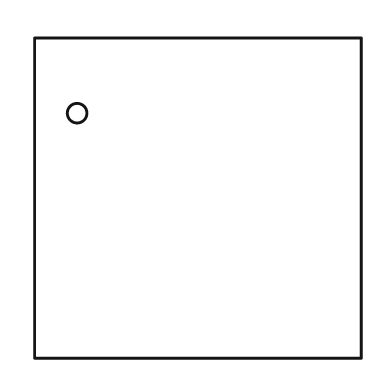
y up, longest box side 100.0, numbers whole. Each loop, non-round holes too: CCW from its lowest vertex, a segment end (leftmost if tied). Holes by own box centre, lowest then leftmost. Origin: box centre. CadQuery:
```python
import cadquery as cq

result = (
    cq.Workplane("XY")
    .moveTo(-50.0, -49.0)
    .lineTo(50.0, -49.0)
    .lineTo(50.0, 49.0)
    .lineTo(-50.0, 49.0)
    .close()
    .moveTo(-37.0, 26.0)
    .circle(3.0)
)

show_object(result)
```